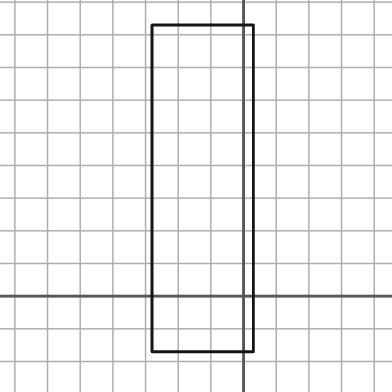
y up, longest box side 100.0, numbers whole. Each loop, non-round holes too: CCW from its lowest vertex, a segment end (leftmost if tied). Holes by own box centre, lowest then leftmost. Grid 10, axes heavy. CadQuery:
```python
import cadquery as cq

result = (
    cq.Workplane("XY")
    .moveTo(-28.0, -17.0)
    .lineTo(3.0, -17.0)
    .lineTo(3.0, 83.0)
    .lineTo(-28.0, 83.0)
    .close()
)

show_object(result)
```